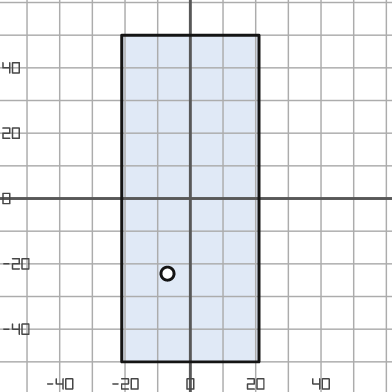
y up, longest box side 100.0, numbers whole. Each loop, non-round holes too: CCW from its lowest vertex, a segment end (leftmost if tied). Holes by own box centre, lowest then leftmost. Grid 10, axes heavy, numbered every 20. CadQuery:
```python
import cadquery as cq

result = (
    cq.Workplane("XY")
    .moveTo(-21.0, -50.0)
    .lineTo(21.0, -50.0)
    .lineTo(21.0, 50.0)
    .lineTo(-21.0, 50.0)
    .close()
    .moveTo(-7.0, -23.0)
    .circle(2.0)
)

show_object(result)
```